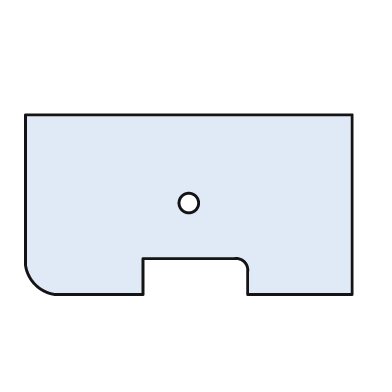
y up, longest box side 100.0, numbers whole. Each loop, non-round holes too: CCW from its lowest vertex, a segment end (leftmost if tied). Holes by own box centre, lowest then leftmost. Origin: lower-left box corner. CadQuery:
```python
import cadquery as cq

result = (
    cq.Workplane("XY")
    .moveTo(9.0, 0.0)
    .lineTo(36.0, 0.0)
    .lineTo(36.0, 11.0)
    .lineTo(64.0, 11.0)
    .threePointArc((67.0, 10.0), (68.0, 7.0))
    .lineTo(68.0, 0.0)
    .lineTo(100.0, 0.0)
    .lineTo(100.0, 55.0)
    .lineTo(0.0, 55.0)
    .lineTo(0.0, 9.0)
    .threePointArc((3.0, 3.0), (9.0, 0.0))
    .close()
    .moveTo(50.0, 28.0)
    .circle(3.0)
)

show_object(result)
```